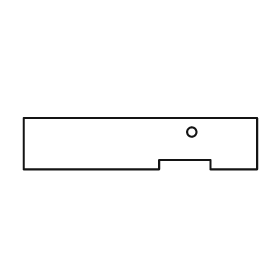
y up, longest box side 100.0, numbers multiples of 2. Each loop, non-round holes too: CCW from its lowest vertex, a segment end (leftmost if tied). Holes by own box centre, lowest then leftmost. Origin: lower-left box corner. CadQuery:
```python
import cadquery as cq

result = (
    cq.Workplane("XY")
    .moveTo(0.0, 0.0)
    .lineTo(58.0, 0.0)
    .lineTo(58.0, 4.0)
    .lineTo(80.0, 4.0)
    .lineTo(80.0, 0.0)
    .lineTo(100.0, 0.0)
    .lineTo(100.0, 22.0)
    .lineTo(0.0, 22.0)
    .close()
    .moveTo(72.0, 16.0)
    .circle(2.0)
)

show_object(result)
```